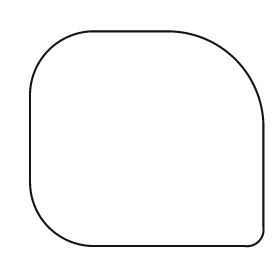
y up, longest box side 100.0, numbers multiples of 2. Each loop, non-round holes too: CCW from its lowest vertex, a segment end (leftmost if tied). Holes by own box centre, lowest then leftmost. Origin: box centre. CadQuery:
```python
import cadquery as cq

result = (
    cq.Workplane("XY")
    .moveTo(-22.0, -46.0)
    .lineTo(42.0, -46.0)
    .threePointArc((48.0, -44.0), (50.0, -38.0))
    .lineTo(50.0, 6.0)
    .threePointArc((38.0, 34.0), (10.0, 46.0))
    .lineTo(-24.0, 46.0)
    .threePointArc((-42.0, 38.0), (-50.0, 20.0))
    .lineTo(-50.0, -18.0)
    .threePointArc((-42.0, -38.0), (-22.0, -46.0))
    .close()
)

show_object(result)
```